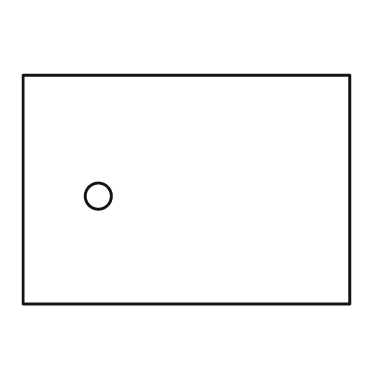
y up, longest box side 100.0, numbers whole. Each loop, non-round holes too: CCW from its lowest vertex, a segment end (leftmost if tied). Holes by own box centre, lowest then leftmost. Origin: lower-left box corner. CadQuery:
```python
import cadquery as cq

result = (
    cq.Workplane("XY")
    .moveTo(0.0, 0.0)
    .lineTo(100.0, 0.0)
    .lineTo(100.0, 70.0)
    .lineTo(0.0, 70.0)
    .close()
    .moveTo(23.0, 33.0)
    .circle(4.0)
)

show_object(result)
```